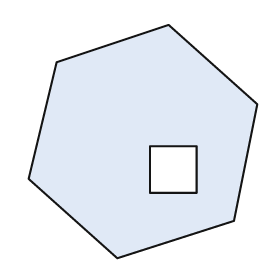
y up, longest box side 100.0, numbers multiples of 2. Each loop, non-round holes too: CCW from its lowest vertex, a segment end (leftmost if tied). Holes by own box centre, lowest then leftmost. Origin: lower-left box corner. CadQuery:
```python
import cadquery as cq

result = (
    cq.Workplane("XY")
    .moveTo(38.0, 0.0)
    .lineTo(88.0, 16.0)
    .lineTo(98.0, 66.0)
    .lineTo(60.0, 100.0)
    .lineTo(12.0, 84.0)
    .lineTo(0.0, 34.0)
    .close()
    .moveTo(52.0, 28.0)
    .lineTo(72.0, 28.0)
    .lineTo(72.0, 48.0)
    .lineTo(52.0, 48.0)
    .close()
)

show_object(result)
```